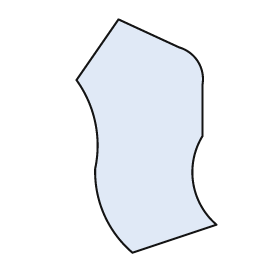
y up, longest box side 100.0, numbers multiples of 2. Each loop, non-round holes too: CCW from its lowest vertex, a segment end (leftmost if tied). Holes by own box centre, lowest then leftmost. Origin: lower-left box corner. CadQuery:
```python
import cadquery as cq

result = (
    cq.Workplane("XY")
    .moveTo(24.0, 0.0)
    .lineTo(60.0, 12.0)
    .threePointArc((50.0, 30.0), (54.0, 50.0))
    .lineTo(54.0, 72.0)
    .threePointArc((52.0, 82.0), (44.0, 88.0))
    .lineTo(18.0, 100.0)
    .lineTo(0.0, 74.0)
    .threePointArc((8.0, 56.0), (8.0, 36.0))
    .threePointArc((12.0, 16.0), (24.0, 0.0))
    .close()
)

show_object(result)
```